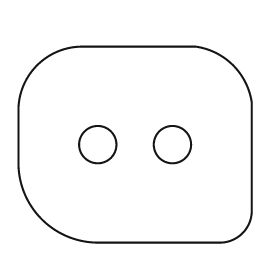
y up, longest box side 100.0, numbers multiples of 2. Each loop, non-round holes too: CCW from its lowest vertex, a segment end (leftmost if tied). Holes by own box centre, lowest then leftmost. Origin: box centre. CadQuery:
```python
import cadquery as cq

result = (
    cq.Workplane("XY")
    .moveTo(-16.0, -42.0)
    .lineTo(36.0, -42.0)
    .threePointArc((46.0, -38.0), (50.0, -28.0))
    .lineTo(50.0, 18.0)
    .threePointArc((42.0, 34.0), (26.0, 42.0))
    .lineTo(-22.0, 42.0)
    .threePointArc((-42.0, 34.0), (-50.0, 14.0))
    .lineTo(-50.0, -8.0)
    .threePointArc((-40.0, -32.0), (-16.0, -42.0))
    .close()
    .moveTo(-16.0, 0.0)
    .circle(8.0)
    .moveTo(16.0, 0.0)
    .circle(8.0)
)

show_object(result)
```